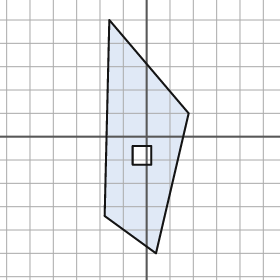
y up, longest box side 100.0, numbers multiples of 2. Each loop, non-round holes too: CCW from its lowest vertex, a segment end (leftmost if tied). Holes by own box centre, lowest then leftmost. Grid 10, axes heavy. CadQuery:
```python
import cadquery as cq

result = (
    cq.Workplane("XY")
    .moveTo(4.0, -50.0)
    .lineTo(18.0, 10.0)
    .lineTo(-16.0, 50.0)
    .lineTo(-18.0, -34.0)
    .close()
    .moveTo(-6.0, -12.0)
    .lineTo(2.0, -12.0)
    .lineTo(2.0, -4.0)
    .lineTo(-6.0, -4.0)
    .close()
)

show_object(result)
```